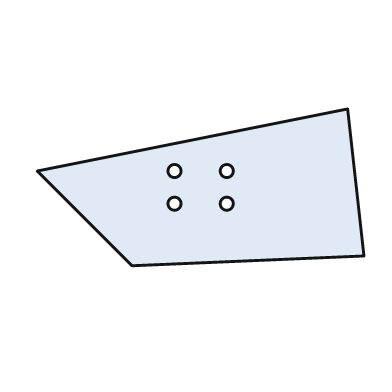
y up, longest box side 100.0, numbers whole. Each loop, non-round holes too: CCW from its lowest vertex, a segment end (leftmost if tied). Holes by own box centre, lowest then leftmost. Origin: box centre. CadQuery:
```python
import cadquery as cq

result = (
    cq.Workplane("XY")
    .moveTo(-21.0, -24.0)
    .lineTo(50.0, -21.0)
    .lineTo(45.0, 24.0)
    .lineTo(-50.0, 5.0)
    .close()
    .moveTo(-8.0, -5.0)
    .circle(2.0)
    .moveTo(8.0, -5.0)
    .circle(2.0)
    .moveTo(-8.0, 5.0)
    .circle(2.0)
    .moveTo(8.0, 5.0)
    .circle(2.0)
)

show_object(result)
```